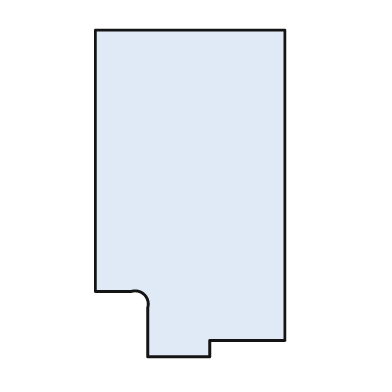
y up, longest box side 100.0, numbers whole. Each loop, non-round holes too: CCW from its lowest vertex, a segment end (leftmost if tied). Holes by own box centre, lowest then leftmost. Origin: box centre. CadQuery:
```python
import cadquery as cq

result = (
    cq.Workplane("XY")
    .moveTo(-13.0, -50.0)
    .lineTo(6.0, -50.0)
    .lineTo(6.0, -45.0)
    .lineTo(29.0, -45.0)
    .lineTo(29.0, 50.0)
    .lineTo(-29.0, 50.0)
    .lineTo(-29.0, -30.0)
    .lineTo(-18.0, -30.0)
    .threePointArc((-14.0, -31.0), (-13.0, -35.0))
    .close()
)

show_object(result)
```